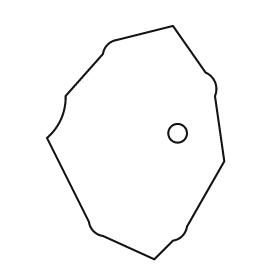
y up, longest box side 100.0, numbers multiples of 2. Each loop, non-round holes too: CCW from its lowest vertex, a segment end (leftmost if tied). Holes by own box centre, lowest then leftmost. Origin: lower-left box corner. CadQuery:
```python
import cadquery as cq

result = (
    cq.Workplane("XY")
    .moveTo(46.0, 0.0)
    .lineTo(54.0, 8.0)
    .threePointArc((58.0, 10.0), (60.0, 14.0))
    .lineTo(76.0, 42.0)
    .lineTo(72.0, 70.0)
    .threePointArc((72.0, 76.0), (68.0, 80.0))
    .lineTo(54.0, 100.0)
    .lineTo(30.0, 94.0)
    .threePointArc((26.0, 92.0), (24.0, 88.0))
    .lineTo(8.0, 70.0)
    .threePointArc((6.0, 60.0), (0.0, 52.0))
    .lineTo(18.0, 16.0)
    .threePointArc((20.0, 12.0), (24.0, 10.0))
    .close()
    .moveTo(56.0, 54.0)
    .circle(4.0)
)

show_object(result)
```